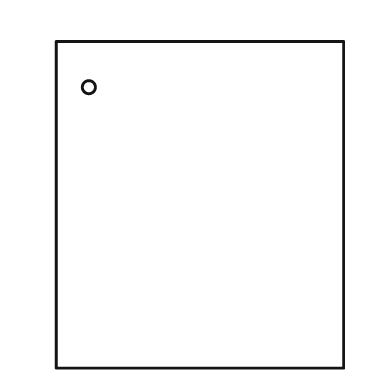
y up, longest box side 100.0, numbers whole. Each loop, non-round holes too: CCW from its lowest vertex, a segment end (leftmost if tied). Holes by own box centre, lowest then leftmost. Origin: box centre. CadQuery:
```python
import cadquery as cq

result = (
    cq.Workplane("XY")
    .moveTo(-44.0, -50.0)
    .lineTo(44.0, -50.0)
    .lineTo(44.0, 50.0)
    .lineTo(-44.0, 50.0)
    .close()
    .moveTo(-34.0, 36.0)
    .circle(2.0)
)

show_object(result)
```